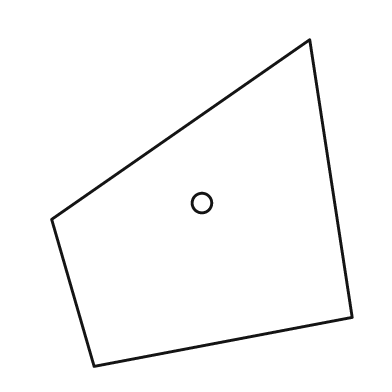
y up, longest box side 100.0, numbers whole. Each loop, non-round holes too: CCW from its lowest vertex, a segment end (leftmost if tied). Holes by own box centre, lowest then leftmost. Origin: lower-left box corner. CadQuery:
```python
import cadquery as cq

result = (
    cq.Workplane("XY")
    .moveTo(13.0, 0.0)
    .lineTo(92.0, 15.0)
    .lineTo(79.0, 100.0)
    .lineTo(0.0, 45.0)
    .close()
    .moveTo(46.0, 50.0)
    .circle(3.0)
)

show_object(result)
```